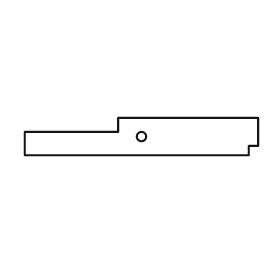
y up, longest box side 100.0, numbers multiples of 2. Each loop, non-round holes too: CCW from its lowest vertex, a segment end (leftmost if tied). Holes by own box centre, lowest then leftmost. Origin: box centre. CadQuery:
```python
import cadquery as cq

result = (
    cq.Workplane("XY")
    .moveTo(-50.0, -8.0)
    .lineTo(46.0, -8.0)
    .lineTo(46.0, -4.0)
    .lineTo(50.0, -4.0)
    .lineTo(50.0, 8.0)
    .lineTo(-10.0, 8.0)
    .lineTo(-10.0, 2.0)
    .lineTo(-50.0, 2.0)
    .close()
    .moveTo(0.0, 0.0)
    .circle(2.0)
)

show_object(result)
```